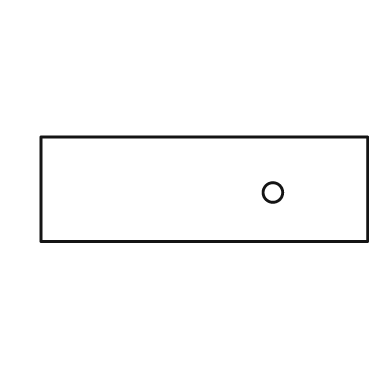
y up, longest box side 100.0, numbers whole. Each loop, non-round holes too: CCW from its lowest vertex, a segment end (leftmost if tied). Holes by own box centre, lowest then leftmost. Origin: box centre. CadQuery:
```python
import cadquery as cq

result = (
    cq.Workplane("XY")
    .moveTo(-50.0, -16.0)
    .lineTo(50.0, -16.0)
    .lineTo(50.0, 16.0)
    .lineTo(-50.0, 16.0)
    .close()
    .moveTo(21.0, -1.0)
    .circle(3.0)
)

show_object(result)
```